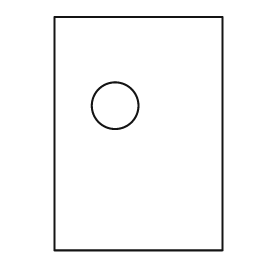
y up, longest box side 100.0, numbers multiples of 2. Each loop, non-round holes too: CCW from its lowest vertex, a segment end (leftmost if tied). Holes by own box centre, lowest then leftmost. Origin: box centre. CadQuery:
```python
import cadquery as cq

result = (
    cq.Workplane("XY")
    .moveTo(-36.0, -50.0)
    .lineTo(36.0, -50.0)
    .lineTo(36.0, 50.0)
    .lineTo(-36.0, 50.0)
    .close()
    .moveTo(-10.0, 12.0)
    .circle(10.0)
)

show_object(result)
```